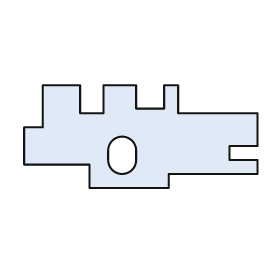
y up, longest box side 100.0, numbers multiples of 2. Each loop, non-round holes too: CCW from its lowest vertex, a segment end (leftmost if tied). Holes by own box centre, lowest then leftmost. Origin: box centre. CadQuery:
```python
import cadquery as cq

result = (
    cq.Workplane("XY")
    .moveTo(-22.0, -22.0)
    .lineTo(12.0, -22.0)
    .lineTo(12.0, -16.0)
    .lineTo(50.0, -16.0)
    .lineTo(50.0, -10.0)
    .lineTo(38.0, -10.0)
    .lineTo(38.0, -4.0)
    .lineTo(50.0, -4.0)
    .lineTo(50.0, 10.0)
    .lineTo(16.0, 10.0)
    .lineTo(16.0, 22.0)
    .lineTo(10.0, 22.0)
    .lineTo(10.0, 12.0)
    .lineTo(-2.0, 12.0)
    .lineTo(-2.0, 22.0)
    .lineTo(-16.0, 22.0)
    .lineTo(-16.0, 10.0)
    .lineTo(-26.0, 10.0)
    .lineTo(-26.0, 22.0)
    .lineTo(-42.0, 22.0)
    .lineTo(-42.0, 4.0)
    .lineTo(-50.0, 4.0)
    .lineTo(-50.0, -12.0)
    .lineTo(-22.0, -12.0)
    .close()
    .moveTo(-14.0, -10.0)
    .threePointArc((-8.0, -16.0), (-2.0, -10.0))
    .lineTo(-2.0, -6.0)
    .threePointArc((-8.0, 0.0), (-14.0, -6.0))
    .close()
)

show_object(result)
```